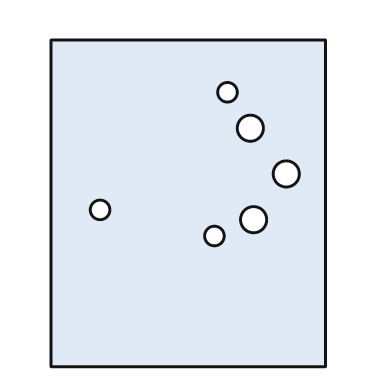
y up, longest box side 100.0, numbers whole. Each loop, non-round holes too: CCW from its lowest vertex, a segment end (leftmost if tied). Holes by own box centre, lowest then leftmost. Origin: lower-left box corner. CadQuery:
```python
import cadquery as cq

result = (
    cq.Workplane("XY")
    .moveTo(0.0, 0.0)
    .lineTo(84.0, 0.0)
    .lineTo(84.0, 100.0)
    .lineTo(0.0, 100.0)
    .close()
    .moveTo(50.0, 40.0)
    .circle(3.0)
    .moveTo(62.0, 45.0)
    .circle(4.0)
    .moveTo(15.0, 48.0)
    .circle(3.0)
    .moveTo(72.0, 59.0)
    .circle(4.0)
    .moveTo(61.0, 73.0)
    .circle(4.0)
    .moveTo(54.0, 84.0)
    .circle(3.0)
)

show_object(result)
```